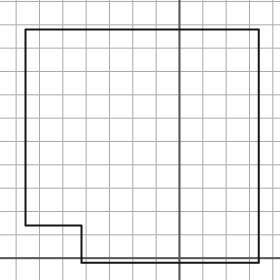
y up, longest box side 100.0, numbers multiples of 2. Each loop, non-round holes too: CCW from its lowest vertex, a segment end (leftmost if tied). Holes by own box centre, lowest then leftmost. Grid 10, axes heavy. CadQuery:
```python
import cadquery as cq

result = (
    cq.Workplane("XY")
    .moveTo(-42.0, -2.0)
    .lineTo(34.0, -2.0)
    .lineTo(34.0, 98.0)
    .lineTo(-66.0, 98.0)
    .lineTo(-66.0, 14.0)
    .lineTo(-42.0, 14.0)
    .close()
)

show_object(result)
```